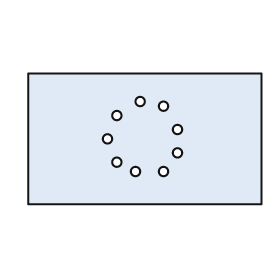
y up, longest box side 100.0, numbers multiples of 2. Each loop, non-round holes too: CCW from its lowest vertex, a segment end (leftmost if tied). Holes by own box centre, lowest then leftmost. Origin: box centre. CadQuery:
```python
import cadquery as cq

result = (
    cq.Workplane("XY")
    .moveTo(-50.0, -28.0)
    .lineTo(50.0, -28.0)
    .lineTo(50.0, 28.0)
    .lineTo(-50.0, 28.0)
    .close()
    .moveTo(-4.0, -14.0)
    .circle(2.0)
    .moveTo(8.0, -14.0)
    .circle(2.0)
    .moveTo(-12.0, -10.0)
    .circle(2.0)
    .moveTo(14.0, -6.0)
    .circle(2.0)
    .moveTo(-16.0, 0.0)
    .circle(2.0)
    .moveTo(14.0, 4.0)
    .circle(2.0)
    .moveTo(-12.0, 10.0)
    .circle(2.0)
    .moveTo(8.0, 14.0)
    .circle(2.0)
    .moveTo(-2.0, 16.0)
    .circle(2.0)
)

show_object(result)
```